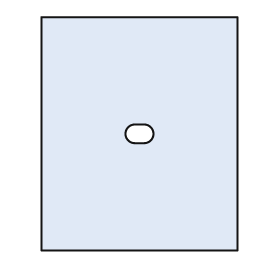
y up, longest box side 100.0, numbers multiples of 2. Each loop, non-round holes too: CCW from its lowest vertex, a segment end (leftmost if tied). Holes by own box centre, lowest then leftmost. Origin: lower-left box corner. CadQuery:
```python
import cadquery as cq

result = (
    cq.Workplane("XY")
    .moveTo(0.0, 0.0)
    .lineTo(84.0, 0.0)
    .lineTo(84.0, 100.0)
    .lineTo(0.0, 100.0)
    .close()
    .moveTo(40.0, 46.0)
    .lineTo(44.0, 46.0)
    .threePointArc((48.0, 50.0), (44.0, 54.0))
    .lineTo(40.0, 54.0)
    .threePointArc((36.0, 50.0), (40.0, 46.0))
    .close()
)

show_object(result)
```